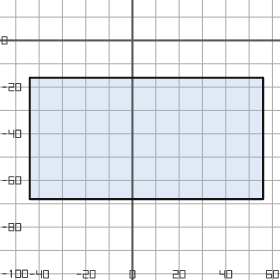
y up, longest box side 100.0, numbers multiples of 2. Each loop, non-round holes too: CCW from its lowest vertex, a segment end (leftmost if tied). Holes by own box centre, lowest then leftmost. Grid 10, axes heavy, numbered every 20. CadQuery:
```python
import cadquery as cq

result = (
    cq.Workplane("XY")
    .moveTo(-44.0, -68.0)
    .lineTo(56.0, -68.0)
    .lineTo(56.0, -16.0)
    .lineTo(-44.0, -16.0)
    .close()
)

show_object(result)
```